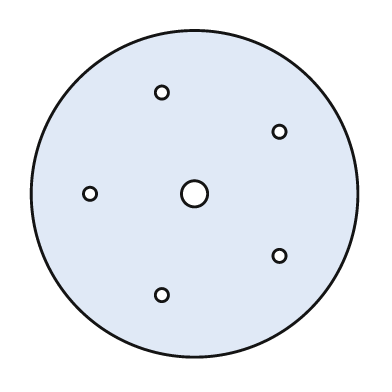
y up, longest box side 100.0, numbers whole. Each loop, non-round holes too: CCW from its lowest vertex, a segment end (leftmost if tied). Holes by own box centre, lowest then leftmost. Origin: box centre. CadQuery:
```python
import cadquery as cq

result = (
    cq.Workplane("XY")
    .moveTo(0.0, 0.0)
    .circle(50.0)
    .moveTo(-10.0, -31.0)
    .circle(2.0)
    .moveTo(26.0, -19.0)
    .circle(2.0)
    .moveTo(-32.0, 0.0)
    .circle(2.0)
    .moveTo(0.0, 0.0)
    .circle(4.0)
    .moveTo(26.0, 19.0)
    .circle(2.0)
    .moveTo(-10.0, 31.0)
    .circle(2.0)
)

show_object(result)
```